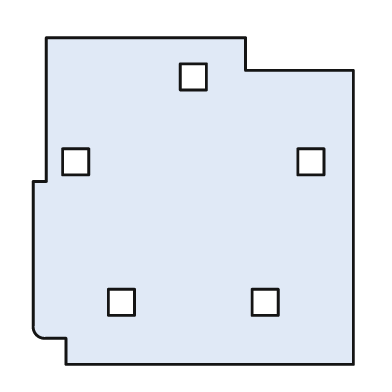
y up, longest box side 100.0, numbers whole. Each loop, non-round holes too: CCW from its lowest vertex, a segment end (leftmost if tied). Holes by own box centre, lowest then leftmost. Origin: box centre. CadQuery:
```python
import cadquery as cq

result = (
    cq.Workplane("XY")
    .moveTo(-39.0, -50.0)
    .lineTo(49.0, -50.0)
    .lineTo(49.0, 40.0)
    .lineTo(16.0, 40.0)
    .lineTo(16.0, 50.0)
    .lineTo(-45.0, 50.0)
    .lineTo(-45.0, 6.0)
    .lineTo(-49.0, 6.0)
    .lineTo(-49.0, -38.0)
    .threePointArc((-48.0, -41.0), (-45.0, -42.0))
    .lineTo(-39.0, -42.0)
    .close()
    .moveTo(-26.0, -35.0)
    .lineTo(-18.0, -35.0)
    .lineTo(-18.0, -27.0)
    .lineTo(-26.0, -27.0)
    .close()
    .moveTo(18.0, -35.0)
    .lineTo(26.0, -35.0)
    .lineTo(26.0, -27.0)
    .lineTo(18.0, -27.0)
    .close()
    .moveTo(-40.0, 8.0)
    .lineTo(-32.0, 8.0)
    .lineTo(-32.0, 16.0)
    .lineTo(-40.0, 16.0)
    .close()
    .moveTo(32.0, 8.0)
    .lineTo(40.0, 8.0)
    .lineTo(40.0, 16.0)
    .lineTo(32.0, 16.0)
    .close()
    .moveTo(-4.0, 34.0)
    .lineTo(4.0, 34.0)
    .lineTo(4.0, 42.0)
    .lineTo(-4.0, 42.0)
    .close()
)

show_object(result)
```